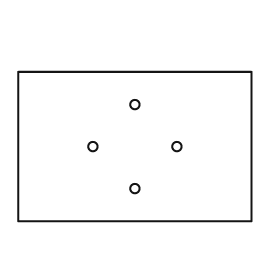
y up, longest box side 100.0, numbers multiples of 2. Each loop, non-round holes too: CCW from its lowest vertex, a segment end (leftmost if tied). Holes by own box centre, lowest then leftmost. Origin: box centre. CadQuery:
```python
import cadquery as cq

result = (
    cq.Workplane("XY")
    .moveTo(-50.0, -32.0)
    .lineTo(50.0, -32.0)
    .lineTo(50.0, 32.0)
    .lineTo(-50.0, 32.0)
    .close()
    .moveTo(0.0, -18.0)
    .circle(2.0)
    .moveTo(-18.0, 0.0)
    .circle(2.0)
    .moveTo(18.0, 0.0)
    .circle(2.0)
    .moveTo(0.0, 18.0)
    .circle(2.0)
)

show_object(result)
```